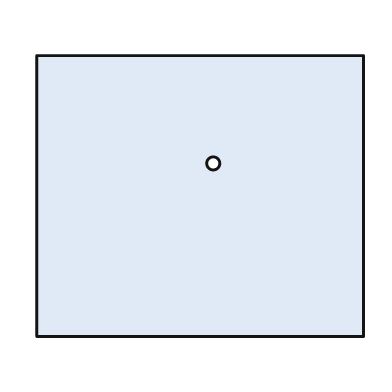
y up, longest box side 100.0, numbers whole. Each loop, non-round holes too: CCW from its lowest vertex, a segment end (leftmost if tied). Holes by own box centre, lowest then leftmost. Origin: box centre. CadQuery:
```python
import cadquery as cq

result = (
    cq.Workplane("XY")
    .moveTo(-50.0, -43.0)
    .lineTo(50.0, -43.0)
    .lineTo(50.0, 43.0)
    .lineTo(-50.0, 43.0)
    .close()
    .moveTo(4.0, 10.0)
    .circle(2.0)
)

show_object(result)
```